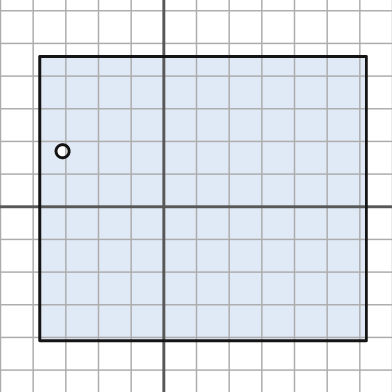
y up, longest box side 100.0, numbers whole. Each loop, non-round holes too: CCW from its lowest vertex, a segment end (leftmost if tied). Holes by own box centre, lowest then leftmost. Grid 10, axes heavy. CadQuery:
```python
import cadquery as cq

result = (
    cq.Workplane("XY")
    .moveTo(-38.0, -41.0)
    .lineTo(62.0, -41.0)
    .lineTo(62.0, 46.0)
    .lineTo(-38.0, 46.0)
    .close()
    .moveTo(-31.0, 17.0)
    .circle(2.0)
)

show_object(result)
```